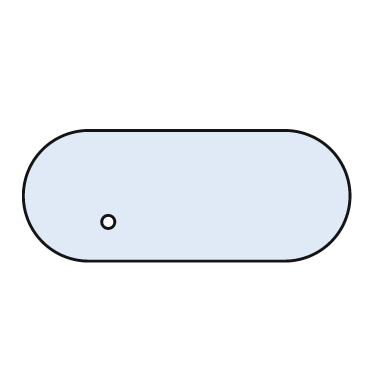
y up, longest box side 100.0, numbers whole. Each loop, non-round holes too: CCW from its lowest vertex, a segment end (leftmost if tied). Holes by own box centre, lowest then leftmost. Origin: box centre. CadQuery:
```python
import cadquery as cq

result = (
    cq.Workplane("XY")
    .moveTo(-30.0, -20.0)
    .lineTo(30.0, -20.0)
    .threePointArc((50.0, 0.0), (30.0, 20.0))
    .lineTo(-30.0, 20.0)
    .threePointArc((-50.0, 0.0), (-30.0, -20.0))
    .close()
    .moveTo(-24.0, -8.0)
    .circle(2.0)
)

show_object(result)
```